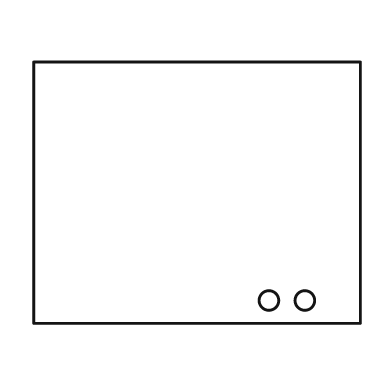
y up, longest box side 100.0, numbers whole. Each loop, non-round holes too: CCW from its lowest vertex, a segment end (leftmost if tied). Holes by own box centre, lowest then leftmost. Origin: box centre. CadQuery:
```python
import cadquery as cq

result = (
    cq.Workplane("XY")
    .moveTo(-50.0, -40.0)
    .lineTo(50.0, -40.0)
    .lineTo(50.0, 40.0)
    .lineTo(-50.0, 40.0)
    .close()
    .moveTo(22.0, -33.0)
    .circle(3.0)
    .moveTo(33.0, -33.0)
    .circle(3.0)
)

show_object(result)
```